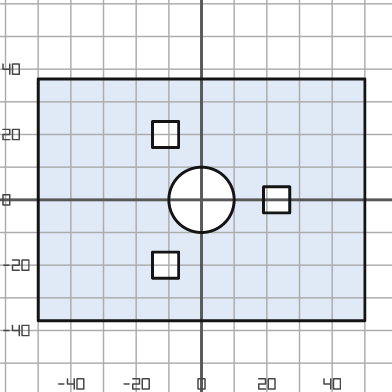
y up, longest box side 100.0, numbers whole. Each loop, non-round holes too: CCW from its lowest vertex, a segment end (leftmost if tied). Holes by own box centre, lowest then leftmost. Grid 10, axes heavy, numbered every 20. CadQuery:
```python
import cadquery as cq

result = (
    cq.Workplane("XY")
    .moveTo(-50.0, -37.0)
    .lineTo(50.0, -37.0)
    .lineTo(50.0, 37.0)
    .lineTo(-50.0, 37.0)
    .close()
    .moveTo(-15.0, -24.0)
    .lineTo(-7.0, -24.0)
    .lineTo(-7.0, -16.0)
    .lineTo(-15.0, -16.0)
    .close()
    .moveTo(0.0, 0.0)
    .circle(10.0)
    .moveTo(19.0, -4.0)
    .lineTo(27.0, -4.0)
    .lineTo(27.0, 4.0)
    .lineTo(19.0, 4.0)
    .close()
    .moveTo(-15.0, 16.0)
    .lineTo(-7.0, 16.0)
    .lineTo(-7.0, 24.0)
    .lineTo(-15.0, 24.0)
    .close()
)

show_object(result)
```